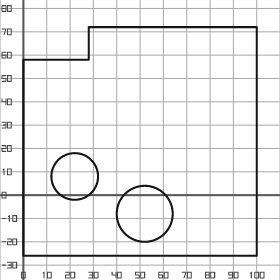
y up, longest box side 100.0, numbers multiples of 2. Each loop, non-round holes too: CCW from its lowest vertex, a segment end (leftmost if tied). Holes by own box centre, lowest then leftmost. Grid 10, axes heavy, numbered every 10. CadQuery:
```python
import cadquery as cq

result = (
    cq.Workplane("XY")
    .moveTo(0.0, -26.0)
    .lineTo(100.0, -26.0)
    .lineTo(100.0, 72.0)
    .lineTo(28.0, 72.0)
    .lineTo(28.0, 58.0)
    .lineTo(0.0, 58.0)
    .close()
    .moveTo(52.0, -8.0)
    .circle(12.0)
    .moveTo(22.0, 8.0)
    .circle(10.0)
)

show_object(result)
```